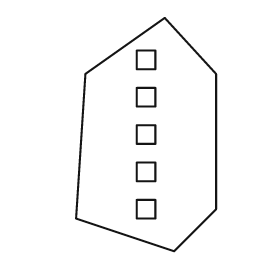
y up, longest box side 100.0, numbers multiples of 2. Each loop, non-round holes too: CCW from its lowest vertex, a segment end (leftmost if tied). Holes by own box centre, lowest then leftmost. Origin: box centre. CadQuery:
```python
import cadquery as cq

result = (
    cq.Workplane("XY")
    .moveTo(12.0, -50.0)
    .lineTo(30.0, -32.0)
    .lineTo(30.0, 26.0)
    .lineTo(8.0, 50.0)
    .lineTo(-26.0, 26.0)
    .lineTo(-30.0, -36.0)
    .close()
    .moveTo(-4.0, -36.0)
    .lineTo(4.0, -36.0)
    .lineTo(4.0, -28.0)
    .lineTo(-4.0, -28.0)
    .close()
    .moveTo(-4.0, -20.0)
    .lineTo(4.0, -20.0)
    .lineTo(4.0, -12.0)
    .lineTo(-4.0, -12.0)
    .close()
    .moveTo(-4.0, -4.0)
    .lineTo(4.0, -4.0)
    .lineTo(4.0, 4.0)
    .lineTo(-4.0, 4.0)
    .close()
    .moveTo(-4.0, 12.0)
    .lineTo(4.0, 12.0)
    .lineTo(4.0, 20.0)
    .lineTo(-4.0, 20.0)
    .close()
    .moveTo(-4.0, 28.0)
    .lineTo(4.0, 28.0)
    .lineTo(4.0, 36.0)
    .lineTo(-4.0, 36.0)
    .close()
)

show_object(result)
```